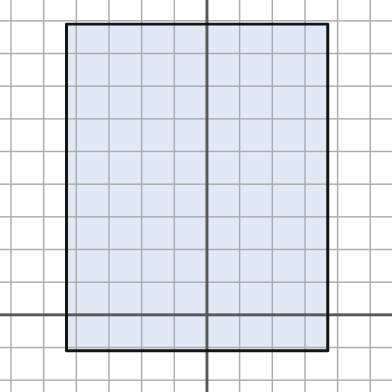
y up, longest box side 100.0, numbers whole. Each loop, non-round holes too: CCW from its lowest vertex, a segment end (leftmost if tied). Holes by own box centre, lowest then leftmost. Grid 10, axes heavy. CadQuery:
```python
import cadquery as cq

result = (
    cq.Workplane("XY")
    .moveTo(-43.0, -11.0)
    .lineTo(37.0, -11.0)
    .lineTo(37.0, 89.0)
    .lineTo(-43.0, 89.0)
    .close()
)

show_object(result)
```